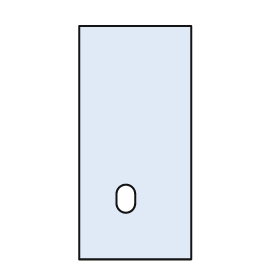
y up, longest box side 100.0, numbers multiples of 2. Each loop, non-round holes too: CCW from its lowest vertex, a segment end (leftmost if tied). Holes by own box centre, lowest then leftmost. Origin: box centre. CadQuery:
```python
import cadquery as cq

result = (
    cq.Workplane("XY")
    .moveTo(-24.0, -50.0)
    .lineTo(24.0, -50.0)
    .lineTo(24.0, 50.0)
    .lineTo(-24.0, 50.0)
    .close()
    .moveTo(-8.0, -26.0)
    .threePointArc((-4.0, -30.0), (0.0, -26.0))
    .lineTo(0.0, -22.0)
    .threePointArc((-4.0, -18.0), (-8.0, -22.0))
    .close()
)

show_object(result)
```